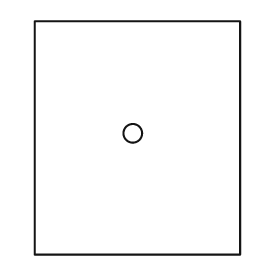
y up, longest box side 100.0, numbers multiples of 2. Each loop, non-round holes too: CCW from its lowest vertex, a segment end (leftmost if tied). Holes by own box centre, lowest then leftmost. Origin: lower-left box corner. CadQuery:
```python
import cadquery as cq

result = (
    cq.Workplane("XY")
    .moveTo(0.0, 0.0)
    .lineTo(88.0, 0.0)
    .lineTo(88.0, 100.0)
    .lineTo(0.0, 100.0)
    .close()
    .moveTo(42.0, 52.0)
    .circle(4.0)
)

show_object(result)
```